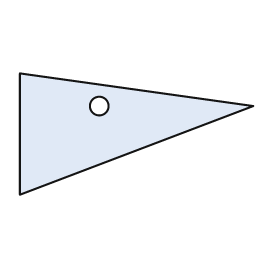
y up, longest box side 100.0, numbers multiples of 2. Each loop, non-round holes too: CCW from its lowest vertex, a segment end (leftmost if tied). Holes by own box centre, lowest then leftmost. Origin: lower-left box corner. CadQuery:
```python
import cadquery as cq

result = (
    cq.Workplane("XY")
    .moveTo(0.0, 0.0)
    .lineTo(100.0, 38.0)
    .lineTo(0.0, 52.0)
    .close()
    .moveTo(34.0, 38.0)
    .circle(4.0)
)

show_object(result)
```